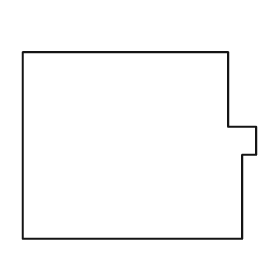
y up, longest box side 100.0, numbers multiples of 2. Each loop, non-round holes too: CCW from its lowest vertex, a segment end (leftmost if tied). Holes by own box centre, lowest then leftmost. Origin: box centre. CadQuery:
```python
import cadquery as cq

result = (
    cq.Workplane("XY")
    .moveTo(-50.0, -40.0)
    .lineTo(44.0, -40.0)
    .lineTo(44.0, -4.0)
    .lineTo(50.0, -4.0)
    .lineTo(50.0, 8.0)
    .lineTo(38.0, 8.0)
    .lineTo(38.0, 40.0)
    .lineTo(-50.0, 40.0)
    .close()
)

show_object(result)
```